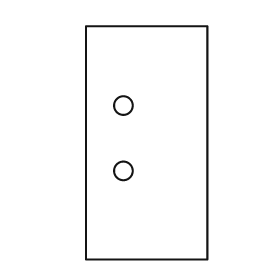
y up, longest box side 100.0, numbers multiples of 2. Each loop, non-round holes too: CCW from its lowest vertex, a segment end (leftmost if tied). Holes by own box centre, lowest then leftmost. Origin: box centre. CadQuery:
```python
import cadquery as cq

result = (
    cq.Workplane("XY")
    .moveTo(-26.0, -50.0)
    .lineTo(26.0, -50.0)
    .lineTo(26.0, 50.0)
    .lineTo(-26.0, 50.0)
    .close()
    .moveTo(-10.0, -12.0)
    .circle(4.0)
    .moveTo(-10.0, 16.0)
    .circle(4.0)
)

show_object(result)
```